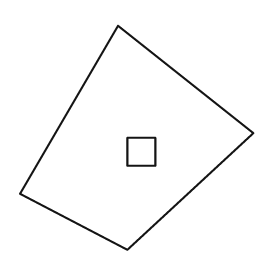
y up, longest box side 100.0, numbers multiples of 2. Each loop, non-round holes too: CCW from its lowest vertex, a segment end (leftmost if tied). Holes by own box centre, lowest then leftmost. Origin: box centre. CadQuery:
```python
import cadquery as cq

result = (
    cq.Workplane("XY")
    .moveTo(-4.0, -48.0)
    .lineTo(50.0, 2.0)
    .lineTo(-8.0, 48.0)
    .lineTo(-50.0, -24.0)
    .close()
    .moveTo(-4.0, -12.0)
    .lineTo(8.0, -12.0)
    .lineTo(8.0, 0.0)
    .lineTo(-4.0, 0.0)
    .close()
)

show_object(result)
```